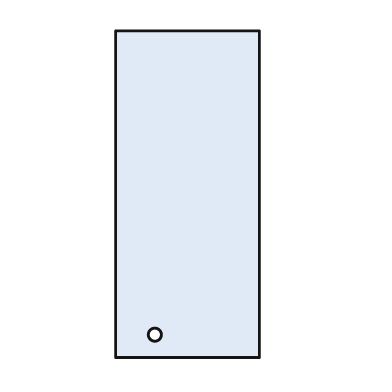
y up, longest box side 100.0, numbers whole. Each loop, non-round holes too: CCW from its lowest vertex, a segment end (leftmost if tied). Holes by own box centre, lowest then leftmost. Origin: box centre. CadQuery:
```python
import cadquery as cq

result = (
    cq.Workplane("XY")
    .moveTo(-22.0, -50.0)
    .lineTo(22.0, -50.0)
    .lineTo(22.0, 50.0)
    .lineTo(-22.0, 50.0)
    .close()
    .moveTo(-10.0, -43.0)
    .circle(2.0)
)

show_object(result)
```